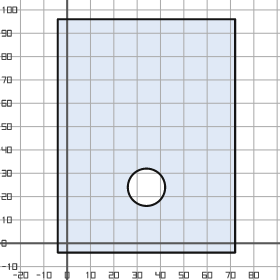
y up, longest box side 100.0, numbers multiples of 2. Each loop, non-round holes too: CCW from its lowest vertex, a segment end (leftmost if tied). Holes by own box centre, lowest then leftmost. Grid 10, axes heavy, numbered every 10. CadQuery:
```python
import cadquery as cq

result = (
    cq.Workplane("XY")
    .moveTo(-4.0, -4.0)
    .lineTo(72.0, -4.0)
    .lineTo(72.0, 96.0)
    .lineTo(-4.0, 96.0)
    .close()
    .moveTo(34.0, 24.0)
    .circle(8.0)
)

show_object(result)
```